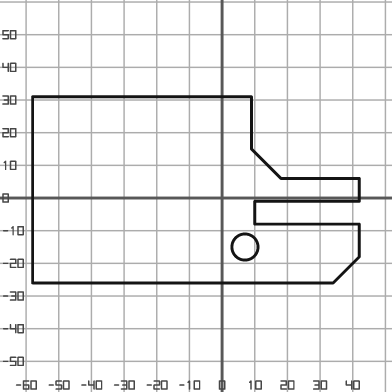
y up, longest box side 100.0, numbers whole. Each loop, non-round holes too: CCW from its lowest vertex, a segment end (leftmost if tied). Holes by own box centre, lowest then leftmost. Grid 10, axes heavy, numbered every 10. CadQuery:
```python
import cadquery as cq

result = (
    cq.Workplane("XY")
    .moveTo(-58.0, -26.0)
    .lineTo(34.0, -26.0)
    .lineTo(42.0, -18.0)
    .lineTo(42.0, -8.0)
    .lineTo(10.0, -8.0)
    .lineTo(10.0, -1.0)
    .lineTo(42.0, -1.0)
    .lineTo(42.0, 6.0)
    .lineTo(18.0, 6.0)
    .lineTo(9.0, 15.0)
    .lineTo(9.0, 31.0)
    .lineTo(-58.0, 31.0)
    .close()
    .moveTo(7.0, -15.0)
    .circle(4.0)
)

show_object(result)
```